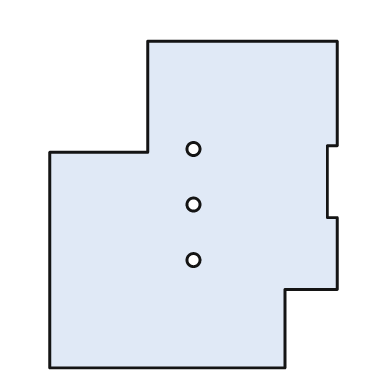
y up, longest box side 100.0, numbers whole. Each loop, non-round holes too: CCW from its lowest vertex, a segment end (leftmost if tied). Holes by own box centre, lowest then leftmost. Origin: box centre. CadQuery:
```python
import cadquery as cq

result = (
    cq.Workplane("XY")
    .moveTo(-44.0, -50.0)
    .lineTo(28.0, -50.0)
    .lineTo(28.0, -26.0)
    .lineTo(44.0, -26.0)
    .lineTo(44.0, -4.0)
    .lineTo(41.0, -4.0)
    .lineTo(41.0, 18.0)
    .lineTo(44.0, 18.0)
    .lineTo(44.0, 50.0)
    .lineTo(-14.0, 50.0)
    .lineTo(-14.0, 16.0)
    .lineTo(-44.0, 16.0)
    .close()
    .moveTo(0.0, -17.0)
    .circle(2.0)
    .moveTo(0.0, 0.0)
    .circle(2.0)
    .moveTo(0.0, 17.0)
    .circle(2.0)
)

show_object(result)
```